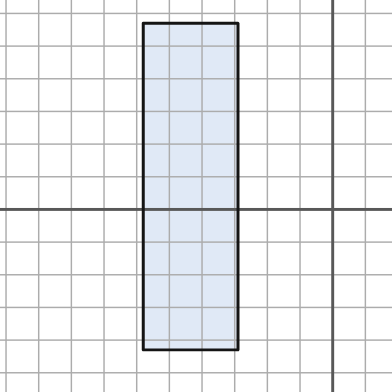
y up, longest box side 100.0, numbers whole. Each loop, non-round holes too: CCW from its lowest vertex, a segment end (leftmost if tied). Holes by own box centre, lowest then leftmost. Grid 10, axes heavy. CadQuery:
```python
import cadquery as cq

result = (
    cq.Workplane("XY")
    .moveTo(-58.0, -43.0)
    .lineTo(-29.0, -43.0)
    .lineTo(-29.0, 57.0)
    .lineTo(-58.0, 57.0)
    .close()
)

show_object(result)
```